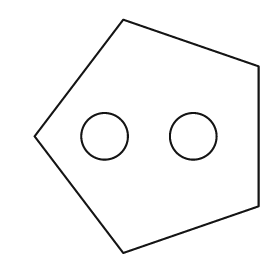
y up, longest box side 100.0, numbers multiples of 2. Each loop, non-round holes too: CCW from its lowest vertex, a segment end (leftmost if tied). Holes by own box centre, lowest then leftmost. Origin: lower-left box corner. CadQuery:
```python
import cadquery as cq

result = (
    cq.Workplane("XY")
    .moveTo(38.0, 0.0)
    .lineTo(96.0, 20.0)
    .lineTo(96.0, 80.0)
    .lineTo(38.0, 100.0)
    .lineTo(0.0, 50.0)
    .close()
    .moveTo(30.0, 50.0)
    .circle(10.0)
    .moveTo(68.0, 50.0)
    .circle(10.0)
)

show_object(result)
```